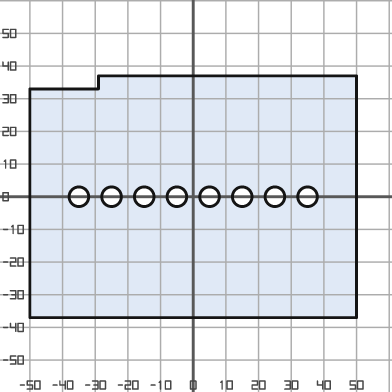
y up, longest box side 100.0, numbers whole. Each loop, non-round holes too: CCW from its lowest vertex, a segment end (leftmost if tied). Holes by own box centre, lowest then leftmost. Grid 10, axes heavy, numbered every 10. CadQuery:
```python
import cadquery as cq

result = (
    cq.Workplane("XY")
    .moveTo(-50.0, -37.0)
    .lineTo(50.0, -37.0)
    .lineTo(50.0, 37.0)
    .lineTo(-29.0, 37.0)
    .lineTo(-29.0, 33.0)
    .lineTo(-50.0, 33.0)
    .close()
    .moveTo(-35.0, 0.0)
    .circle(3.0)
    .moveTo(-25.0, 0.0)
    .circle(3.0)
    .moveTo(-15.0, 0.0)
    .circle(3.0)
    .moveTo(-5.0, 0.0)
    .circle(3.0)
    .moveTo(5.0, 0.0)
    .circle(3.0)
    .moveTo(15.0, 0.0)
    .circle(3.0)
    .moveTo(25.0, 0.0)
    .circle(3.0)
    .moveTo(35.0, 0.0)
    .circle(3.0)
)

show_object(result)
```